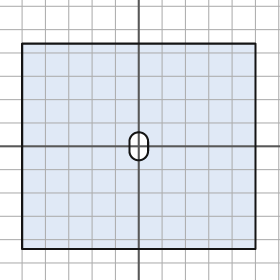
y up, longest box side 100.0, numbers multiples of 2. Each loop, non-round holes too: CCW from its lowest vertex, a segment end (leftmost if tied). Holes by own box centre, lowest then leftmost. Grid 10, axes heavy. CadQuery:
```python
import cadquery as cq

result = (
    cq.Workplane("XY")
    .moveTo(-50.0, -44.0)
    .lineTo(50.0, -44.0)
    .lineTo(50.0, 44.0)
    .lineTo(-50.0, 44.0)
    .close()
    .moveTo(-4.0, -2.0)
    .threePointArc((0.0, -6.0), (4.0, -2.0))
    .lineTo(4.0, 2.0)
    .threePointArc((0.0, 6.0), (-4.0, 2.0))
    .close()
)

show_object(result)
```